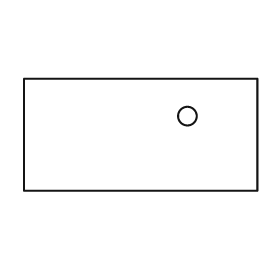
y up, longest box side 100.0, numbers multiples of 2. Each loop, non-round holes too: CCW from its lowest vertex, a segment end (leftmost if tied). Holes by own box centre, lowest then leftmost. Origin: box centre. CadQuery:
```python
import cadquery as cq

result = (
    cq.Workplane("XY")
    .moveTo(-50.0, -24.0)
    .lineTo(50.0, -24.0)
    .lineTo(50.0, 24.0)
    .lineTo(-50.0, 24.0)
    .close()
    .moveTo(20.0, 8.0)
    .circle(4.0)
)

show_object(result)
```